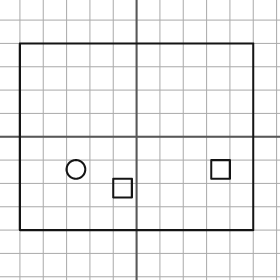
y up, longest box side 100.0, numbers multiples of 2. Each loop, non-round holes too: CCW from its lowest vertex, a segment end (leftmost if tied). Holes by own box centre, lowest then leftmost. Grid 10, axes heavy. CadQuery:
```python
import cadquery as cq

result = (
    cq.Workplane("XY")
    .moveTo(-50.0, -40.0)
    .lineTo(50.0, -40.0)
    .lineTo(50.0, 40.0)
    .lineTo(-50.0, 40.0)
    .close()
    .moveTo(-10.0, -26.0)
    .lineTo(-2.0, -26.0)
    .lineTo(-2.0, -18.0)
    .lineTo(-10.0, -18.0)
    .close()
    .moveTo(-26.0, -14.0)
    .circle(4.0)
    .moveTo(32.0, -18.0)
    .lineTo(40.0, -18.0)
    .lineTo(40.0, -10.0)
    .lineTo(32.0, -10.0)
    .close()
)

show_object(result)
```